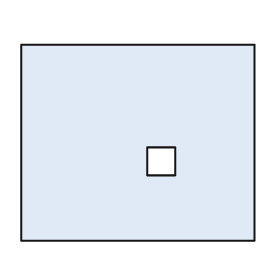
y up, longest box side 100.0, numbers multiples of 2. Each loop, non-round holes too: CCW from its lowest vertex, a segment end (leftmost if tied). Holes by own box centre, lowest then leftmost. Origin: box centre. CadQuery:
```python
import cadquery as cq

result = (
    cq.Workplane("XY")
    .moveTo(-50.0, -42.0)
    .lineTo(50.0, -42.0)
    .lineTo(50.0, 42.0)
    .lineTo(-50.0, 42.0)
    .close()
    .moveTo(4.0, -14.0)
    .lineTo(16.0, -14.0)
    .lineTo(16.0, -2.0)
    .lineTo(4.0, -2.0)
    .close()
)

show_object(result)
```